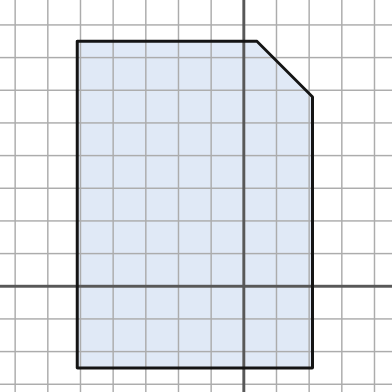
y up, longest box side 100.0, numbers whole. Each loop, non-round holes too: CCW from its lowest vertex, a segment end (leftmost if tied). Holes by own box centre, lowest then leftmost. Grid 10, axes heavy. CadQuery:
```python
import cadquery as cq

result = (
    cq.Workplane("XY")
    .moveTo(-51.0, -25.0)
    .lineTo(21.0, -25.0)
    .lineTo(21.0, 58.0)
    .lineTo(4.0, 75.0)
    .lineTo(-51.0, 75.0)
    .close()
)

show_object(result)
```